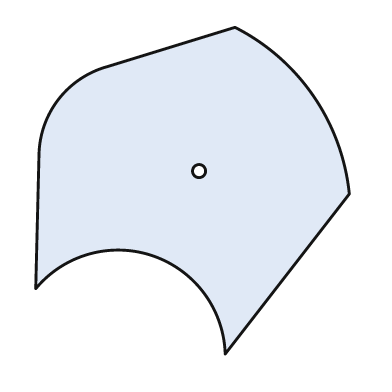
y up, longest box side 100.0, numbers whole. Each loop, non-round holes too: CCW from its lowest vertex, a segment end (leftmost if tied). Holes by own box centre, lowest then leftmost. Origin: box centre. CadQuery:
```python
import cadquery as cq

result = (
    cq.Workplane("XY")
    .moveTo(10.0, -50.0)
    .lineTo(48.0, -1.0)
    .threePointArc((37.0, 29.0), (13.0, 50.0))
    .lineTo(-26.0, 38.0)
    .threePointArc((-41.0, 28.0), (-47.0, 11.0))
    .lineTo(-48.0, -30.0)
    .threePointArc((-12.0, -20.0), (10.0, -50.0))
    .close()
    .moveTo(2.0, 6.0)
    .circle(2.0)
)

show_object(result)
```